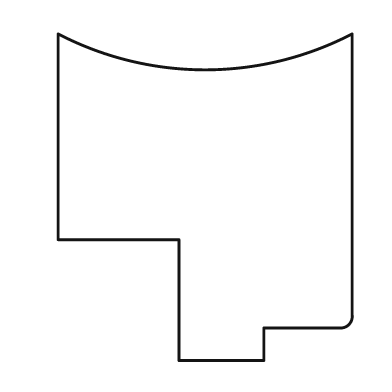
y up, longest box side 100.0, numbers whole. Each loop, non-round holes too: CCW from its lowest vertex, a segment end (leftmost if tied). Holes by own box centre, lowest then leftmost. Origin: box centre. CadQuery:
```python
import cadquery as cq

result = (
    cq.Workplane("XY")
    .moveTo(-8.0, -50.0)
    .lineTo(18.0, -50.0)
    .lineTo(18.0, -40.0)
    .lineTo(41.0, -40.0)
    .threePointArc((44.0, -39.0), (45.0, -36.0))
    .lineTo(45.0, 50.0)
    .threePointArc((0.0, 39.0), (-45.0, 50.0))
    .lineTo(-45.0, -13.0)
    .lineTo(-8.0, -13.0)
    .close()
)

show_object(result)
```